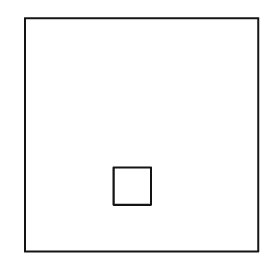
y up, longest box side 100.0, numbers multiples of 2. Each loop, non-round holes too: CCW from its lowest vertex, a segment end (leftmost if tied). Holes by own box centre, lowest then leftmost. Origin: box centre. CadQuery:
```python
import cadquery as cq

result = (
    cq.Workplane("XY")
    .moveTo(-50.0, -50.0)
    .lineTo(50.0, -50.0)
    .lineTo(50.0, 50.0)
    .lineTo(-50.0, 50.0)
    .close()
    .moveTo(-12.0, -30.0)
    .lineTo(4.0, -30.0)
    .lineTo(4.0, -14.0)
    .lineTo(-12.0, -14.0)
    .close()
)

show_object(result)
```